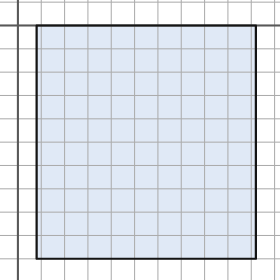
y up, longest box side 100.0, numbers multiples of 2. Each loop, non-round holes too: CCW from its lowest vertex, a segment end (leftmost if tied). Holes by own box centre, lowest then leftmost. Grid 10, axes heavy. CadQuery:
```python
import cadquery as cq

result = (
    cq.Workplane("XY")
    .moveTo(8.0, -100.0)
    .lineTo(102.0, -100.0)
    .lineTo(102.0, 0.0)
    .lineTo(8.0, 0.0)
    .close()
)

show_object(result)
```